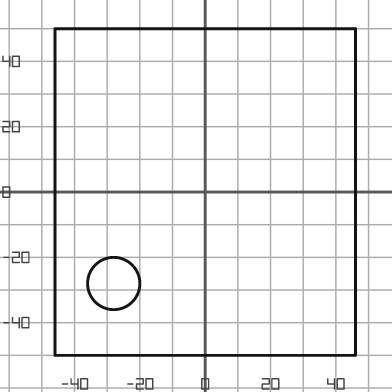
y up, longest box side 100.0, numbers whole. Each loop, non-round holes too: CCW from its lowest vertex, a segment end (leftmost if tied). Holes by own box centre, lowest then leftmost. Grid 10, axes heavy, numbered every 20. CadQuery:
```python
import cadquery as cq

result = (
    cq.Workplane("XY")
    .moveTo(-46.0, -50.0)
    .lineTo(46.0, -50.0)
    .lineTo(46.0, 50.0)
    .lineTo(-46.0, 50.0)
    .close()
    .moveTo(-28.0, -28.0)
    .circle(8.0)
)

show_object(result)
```